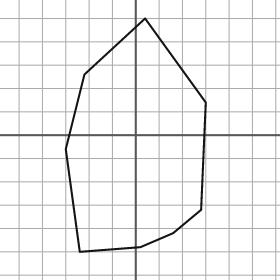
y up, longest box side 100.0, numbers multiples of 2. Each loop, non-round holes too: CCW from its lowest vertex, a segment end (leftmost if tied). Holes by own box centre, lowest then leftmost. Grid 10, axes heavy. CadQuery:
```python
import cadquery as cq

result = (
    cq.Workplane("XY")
    .moveTo(-24.0, -50.0)
    .lineTo(2.0, -48.0)
    .lineTo(16.0, -42.0)
    .lineTo(28.0, -32.0)
    .lineTo(30.0, 14.0)
    .lineTo(4.0, 50.0)
    .lineTo(-22.0, 26.0)
    .lineTo(-30.0, -6.0)
    .close()
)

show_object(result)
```